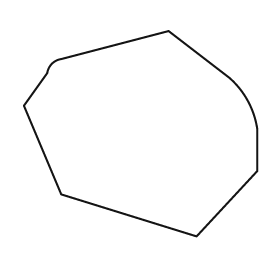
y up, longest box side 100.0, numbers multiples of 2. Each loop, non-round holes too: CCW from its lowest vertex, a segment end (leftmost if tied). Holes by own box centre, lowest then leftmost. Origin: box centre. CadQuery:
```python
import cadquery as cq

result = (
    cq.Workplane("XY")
    .moveTo(24.0, -44.0)
    .lineTo(50.0, -16.0)
    .lineTo(50.0, 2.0)
    .threePointArc((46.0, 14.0), (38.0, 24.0))
    .lineTo(12.0, 44.0)
    .lineTo(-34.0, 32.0)
    .threePointArc((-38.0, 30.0), (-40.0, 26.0))
    .lineTo(-50.0, 12.0)
    .lineTo(-34.0, -26.0)
    .close()
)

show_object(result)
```